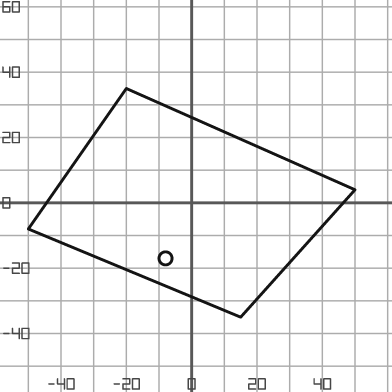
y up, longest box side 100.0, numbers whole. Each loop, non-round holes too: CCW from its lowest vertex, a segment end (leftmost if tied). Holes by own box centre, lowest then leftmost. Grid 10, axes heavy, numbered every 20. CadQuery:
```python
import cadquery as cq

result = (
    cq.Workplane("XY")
    .moveTo(15.0, -35.0)
    .lineTo(50.0, 4.0)
    .lineTo(-20.0, 35.0)
    .lineTo(-50.0, -8.0)
    .close()
    .moveTo(-8.0, -17.0)
    .circle(2.0)
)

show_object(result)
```